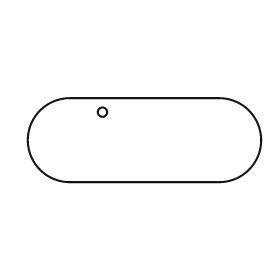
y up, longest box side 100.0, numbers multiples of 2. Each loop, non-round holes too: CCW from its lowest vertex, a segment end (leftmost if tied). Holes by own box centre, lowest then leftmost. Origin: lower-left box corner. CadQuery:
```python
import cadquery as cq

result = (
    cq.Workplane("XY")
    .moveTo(18.0, 0.0)
    .lineTo(82.0, 0.0)
    .threePointArc((100.0, 18.0), (82.0, 36.0))
    .lineTo(18.0, 36.0)
    .threePointArc((0.0, 18.0), (18.0, 0.0))
    .close()
    .moveTo(32.0, 30.0)
    .circle(2.0)
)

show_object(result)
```